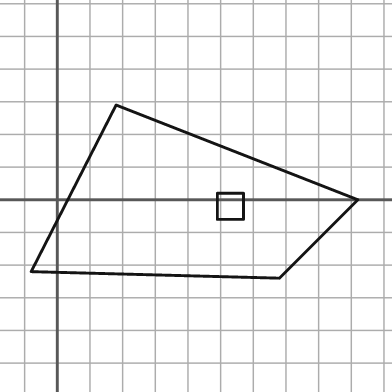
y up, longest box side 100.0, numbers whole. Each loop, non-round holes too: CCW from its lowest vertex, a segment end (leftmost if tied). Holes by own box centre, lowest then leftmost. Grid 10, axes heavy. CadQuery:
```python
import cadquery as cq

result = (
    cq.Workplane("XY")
    .moveTo(68.0, -24.0)
    .lineTo(92.0, 0.0)
    .lineTo(18.0, 29.0)
    .lineTo(-8.0, -22.0)
    .close()
    .moveTo(49.0, -6.0)
    .lineTo(57.0, -6.0)
    .lineTo(57.0, 2.0)
    .lineTo(49.0, 2.0)
    .close()
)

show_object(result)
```